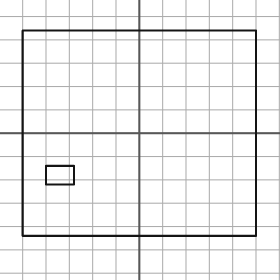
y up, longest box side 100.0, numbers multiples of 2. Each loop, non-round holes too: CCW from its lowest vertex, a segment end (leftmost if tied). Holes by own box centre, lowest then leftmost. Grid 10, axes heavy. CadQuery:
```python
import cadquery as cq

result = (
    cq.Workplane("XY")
    .moveTo(-50.0, -44.0)
    .lineTo(50.0, -44.0)
    .lineTo(50.0, 44.0)
    .lineTo(-50.0, 44.0)
    .close()
    .moveTo(-40.0, -22.0)
    .lineTo(-28.0, -22.0)
    .lineTo(-28.0, -14.0)
    .lineTo(-40.0, -14.0)
    .close()
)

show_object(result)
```